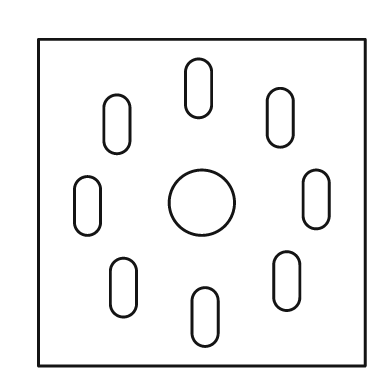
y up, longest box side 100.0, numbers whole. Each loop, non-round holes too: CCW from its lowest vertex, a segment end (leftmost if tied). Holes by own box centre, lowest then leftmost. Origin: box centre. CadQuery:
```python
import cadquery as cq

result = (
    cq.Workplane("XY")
    .moveTo(-50.0, -50.0)
    .lineTo(50.0, -50.0)
    .lineTo(50.0, 50.0)
    .lineTo(-50.0, 50.0)
    .close()
    .moveTo(-3.0, -40.0)
    .threePointArc((1.0, -44.0), (5.0, -40.0))
    .lineTo(5.0, -30.0)
    .threePointArc((1.0, -26.0), (-3.0, -30.0))
    .close()
    .moveTo(-28.0, -31.0)
    .threePointArc((-24.0, -35.0), (-20.0, -31.0))
    .lineTo(-20.0, -21.0)
    .threePointArc((-24.0, -17.0), (-28.0, -21.0))
    .close()
    .moveTo(22.0, -29.0)
    .threePointArc((26.0, -33.0), (30.0, -29.0))
    .lineTo(30.0, -19.0)
    .threePointArc((26.0, -15.0), (22.0, -19.0))
    .close()
    .moveTo(-39.0, -6.0)
    .threePointArc((-35.0, -10.0), (-31.0, -6.0))
    .lineTo(-31.0, 4.0)
    .threePointArc((-35.0, 8.0), (-39.0, 4.0))
    .close()
    .moveTo(0.0, 0.0)
    .circle(10.0)
    .moveTo(31.0, -4.0)
    .threePointArc((35.0, -8.0), (39.0, -4.0))
    .lineTo(39.0, 6.0)
    .threePointArc((35.0, 10.0), (31.0, 6.0))
    .close()
    .moveTo(-30.0, 19.0)
    .threePointArc((-26.0, 15.0), (-22.0, 19.0))
    .lineTo(-22.0, 29.0)
    .threePointArc((-26.0, 33.0), (-30.0, 29.0))
    .close()
    .moveTo(20.0, 21.0)
    .threePointArc((24.0, 17.0), (28.0, 21.0))
    .lineTo(28.0, 31.0)
    .threePointArc((24.0, 35.0), (20.0, 31.0))
    .close()
    .moveTo(-5.0, 30.0)
    .threePointArc((-1.0, 26.0), (3.0, 30.0))
    .lineTo(3.0, 40.0)
    .threePointArc((-1.0, 44.0), (-5.0, 40.0))
    .close()
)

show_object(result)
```